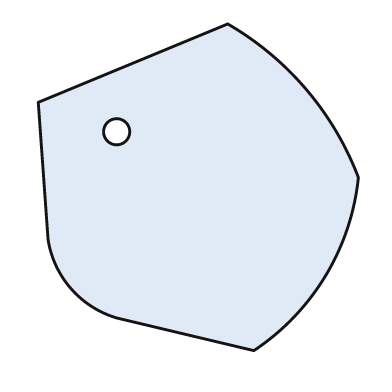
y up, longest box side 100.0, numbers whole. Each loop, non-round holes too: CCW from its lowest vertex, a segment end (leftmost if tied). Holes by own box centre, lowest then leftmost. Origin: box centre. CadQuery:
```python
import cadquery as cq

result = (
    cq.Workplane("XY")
    .moveTo(17.0, -50.0)
    .threePointArc((39.0, -27.0), (49.0, 3.0))
    .threePointArc((33.0, 30.0), (9.0, 50.0))
    .lineTo(-49.0, 26.0)
    .lineTo(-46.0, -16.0)
    .threePointArc((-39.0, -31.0), (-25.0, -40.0))
    .close()
    .moveTo(-25.0, 17.0)
    .circle(4.0)
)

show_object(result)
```